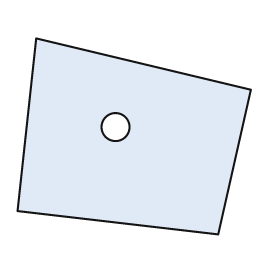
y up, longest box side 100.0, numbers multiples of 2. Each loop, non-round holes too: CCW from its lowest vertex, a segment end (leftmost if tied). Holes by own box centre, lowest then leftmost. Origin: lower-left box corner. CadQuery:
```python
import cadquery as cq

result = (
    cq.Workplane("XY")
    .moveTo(86.0, 0.0)
    .lineTo(100.0, 62.0)
    .lineTo(8.0, 84.0)
    .lineTo(0.0, 10.0)
    .close()
    .moveTo(42.0, 46.0)
    .circle(6.0)
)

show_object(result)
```